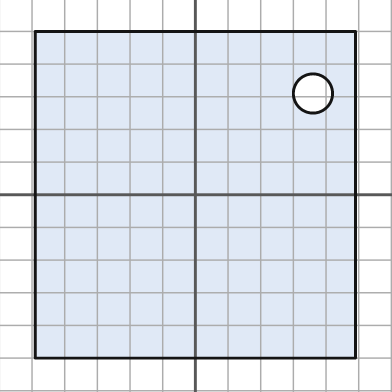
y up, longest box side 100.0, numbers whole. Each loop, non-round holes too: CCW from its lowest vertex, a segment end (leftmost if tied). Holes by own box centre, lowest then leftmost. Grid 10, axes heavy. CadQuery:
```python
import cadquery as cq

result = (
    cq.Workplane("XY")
    .moveTo(-49.0, -50.0)
    .lineTo(49.0, -50.0)
    .lineTo(49.0, 50.0)
    .lineTo(-49.0, 50.0)
    .close()
    .moveTo(36.0, 31.0)
    .circle(6.0)
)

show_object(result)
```